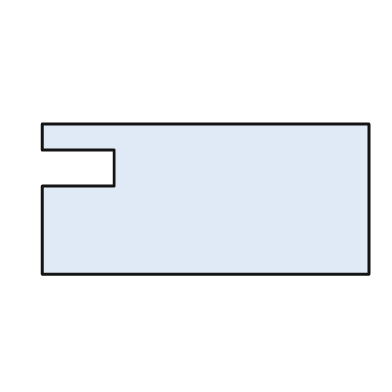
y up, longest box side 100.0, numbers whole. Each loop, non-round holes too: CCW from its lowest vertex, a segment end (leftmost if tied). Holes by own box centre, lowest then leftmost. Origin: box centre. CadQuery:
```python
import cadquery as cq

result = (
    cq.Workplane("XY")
    .moveTo(-50.0, -23.0)
    .lineTo(50.0, -23.0)
    .lineTo(50.0, 23.0)
    .lineTo(-50.0, 23.0)
    .lineTo(-50.0, 15.0)
    .lineTo(-28.0, 15.0)
    .lineTo(-28.0, 4.0)
    .lineTo(-50.0, 4.0)
    .close()
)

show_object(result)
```